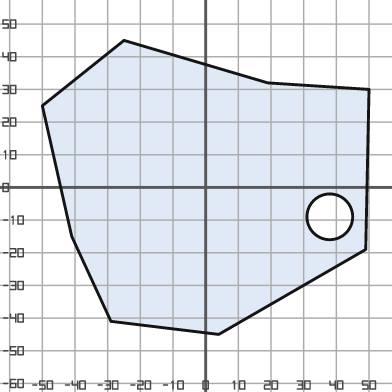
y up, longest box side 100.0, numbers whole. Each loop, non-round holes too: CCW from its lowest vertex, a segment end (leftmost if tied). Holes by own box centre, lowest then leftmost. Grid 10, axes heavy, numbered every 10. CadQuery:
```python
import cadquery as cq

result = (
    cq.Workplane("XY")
    .moveTo(4.0, -45.0)
    .lineTo(49.0, -19.0)
    .lineTo(50.0, 30.0)
    .lineTo(19.0, 32.0)
    .lineTo(-25.0, 45.0)
    .lineTo(-50.0, 25.0)
    .lineTo(-41.0, -15.0)
    .lineTo(-29.0, -41.0)
    .close()
    .moveTo(38.0, -9.0)
    .circle(7.0)
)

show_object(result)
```